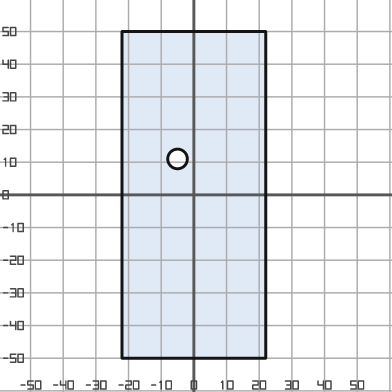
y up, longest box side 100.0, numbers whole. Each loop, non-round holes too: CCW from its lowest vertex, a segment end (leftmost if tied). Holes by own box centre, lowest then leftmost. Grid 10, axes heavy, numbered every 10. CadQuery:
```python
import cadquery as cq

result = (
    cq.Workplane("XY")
    .moveTo(-22.0, -50.0)
    .lineTo(22.0, -50.0)
    .lineTo(22.0, 50.0)
    .lineTo(-22.0, 50.0)
    .close()
    .moveTo(-5.0, 11.0)
    .circle(3.0)
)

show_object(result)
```